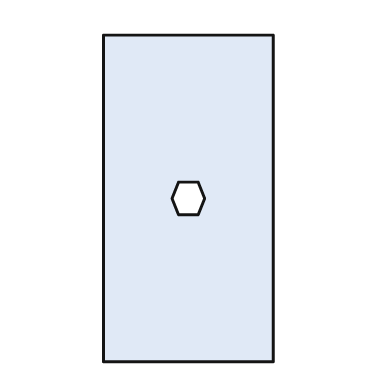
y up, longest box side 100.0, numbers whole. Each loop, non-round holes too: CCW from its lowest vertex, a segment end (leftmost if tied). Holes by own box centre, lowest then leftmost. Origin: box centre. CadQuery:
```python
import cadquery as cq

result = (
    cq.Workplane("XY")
    .moveTo(-26.0, -50.0)
    .lineTo(26.0, -50.0)
    .lineTo(26.0, 50.0)
    .lineTo(-26.0, 50.0)
    .close()
    .moveTo(-3.0, -5.0)
    .lineTo(3.0, -5.0)
    .lineTo(5.0, 0.0)
    .lineTo(3.0, 5.0)
    .lineTo(-3.0, 5.0)
    .lineTo(-5.0, 0.0)
    .close()
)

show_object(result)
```